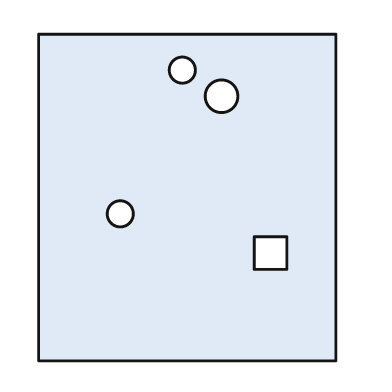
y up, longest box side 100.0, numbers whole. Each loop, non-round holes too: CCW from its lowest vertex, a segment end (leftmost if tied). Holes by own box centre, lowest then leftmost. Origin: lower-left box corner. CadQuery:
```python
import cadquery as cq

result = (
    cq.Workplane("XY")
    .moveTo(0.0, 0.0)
    .lineTo(91.0, 0.0)
    .lineTo(91.0, 100.0)
    .lineTo(0.0, 100.0)
    .close()
    .moveTo(66.0, 28.0)
    .lineTo(76.0, 28.0)
    .lineTo(76.0, 38.0)
    .lineTo(66.0, 38.0)
    .close()
    .moveTo(25.0, 45.0)
    .circle(4.0)
    .moveTo(56.0, 81.0)
    .circle(5.0)
    .moveTo(44.0, 89.0)
    .circle(4.0)
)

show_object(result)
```